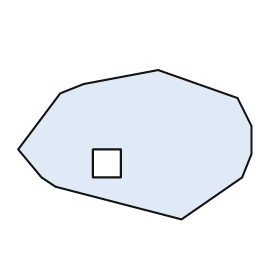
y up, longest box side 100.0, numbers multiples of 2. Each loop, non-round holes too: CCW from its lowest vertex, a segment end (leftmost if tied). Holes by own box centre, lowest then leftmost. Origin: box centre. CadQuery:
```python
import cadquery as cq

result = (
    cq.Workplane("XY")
    .moveTo(20.0, -32.0)
    .lineTo(46.0, -14.0)
    .lineTo(50.0, -4.0)
    .lineTo(50.0, 8.0)
    .lineTo(44.0, 20.0)
    .lineTo(10.0, 32.0)
    .lineTo(-22.0, 26.0)
    .lineTo(-32.0, 22.0)
    .lineTo(-50.0, -2.0)
    .lineTo(-40.0, -14.0)
    .lineTo(-34.0, -18.0)
    .close()
    .moveTo(-18.0, -14.0)
    .lineTo(-6.0, -14.0)
    .lineTo(-6.0, -2.0)
    .lineTo(-18.0, -2.0)
    .close()
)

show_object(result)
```